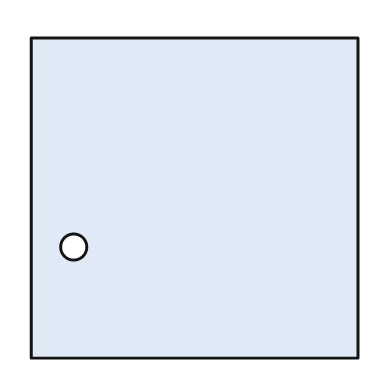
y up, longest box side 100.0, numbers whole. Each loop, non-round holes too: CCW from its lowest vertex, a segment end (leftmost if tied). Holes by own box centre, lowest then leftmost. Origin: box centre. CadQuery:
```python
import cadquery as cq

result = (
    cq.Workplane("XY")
    .moveTo(-50.0, -49.0)
    .lineTo(50.0, -49.0)
    .lineTo(50.0, 49.0)
    .lineTo(-50.0, 49.0)
    .close()
    .moveTo(-37.0, -15.0)
    .circle(4.0)
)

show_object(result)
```